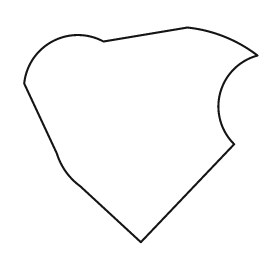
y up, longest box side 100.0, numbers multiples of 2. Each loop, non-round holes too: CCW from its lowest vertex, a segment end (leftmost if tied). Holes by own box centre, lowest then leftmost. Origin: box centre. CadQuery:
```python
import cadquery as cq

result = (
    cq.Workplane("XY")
    .moveTo(0.0, -46.0)
    .lineTo(40.0, -4.0)
    .threePointArc((34.0, 18.0), (50.0, 34.0))
    .threePointArc((36.0, 42.0), (20.0, 46.0))
    .lineTo(-16.0, 40.0)
    .threePointArc((-38.0, 40.0), (-50.0, 22.0))
    .lineTo(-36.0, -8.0)
    .threePointArc((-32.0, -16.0), (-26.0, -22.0))
    .close()
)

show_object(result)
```